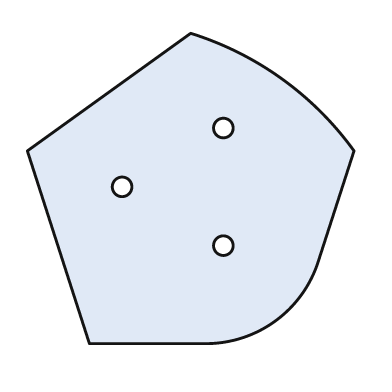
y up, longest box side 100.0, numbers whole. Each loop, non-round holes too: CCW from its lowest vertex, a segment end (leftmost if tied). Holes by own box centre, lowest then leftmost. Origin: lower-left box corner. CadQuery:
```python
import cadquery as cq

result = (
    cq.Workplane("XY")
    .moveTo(19.0, 0.0)
    .lineTo(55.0, 0.0)
    .threePointArc((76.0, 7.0), (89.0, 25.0))
    .lineTo(100.0, 59.0)
    .threePointArc((78.0, 81.0), (50.0, 95.0))
    .lineTo(0.0, 59.0)
    .close()
    .moveTo(60.0, 30.0)
    .circle(3.0)
    .moveTo(29.0, 48.0)
    .circle(3.0)
    .moveTo(60.0, 66.0)
    .circle(3.0)
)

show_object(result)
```